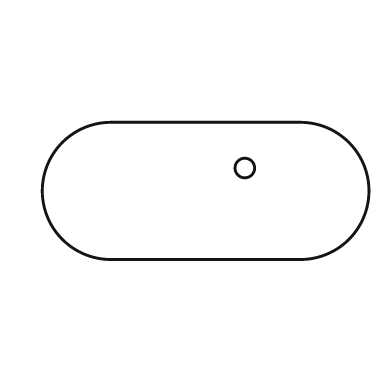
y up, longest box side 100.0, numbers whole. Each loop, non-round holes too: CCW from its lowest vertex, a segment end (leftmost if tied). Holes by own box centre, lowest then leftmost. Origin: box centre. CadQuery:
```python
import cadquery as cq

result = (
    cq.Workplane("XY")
    .moveTo(-29.0, -21.0)
    .lineTo(29.0, -21.0)
    .threePointArc((50.0, 0.0), (29.0, 21.0))
    .lineTo(-29.0, 21.0)
    .threePointArc((-50.0, 0.0), (-29.0, -21.0))
    .close()
    .moveTo(12.0, 7.0)
    .circle(3.0)
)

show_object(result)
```